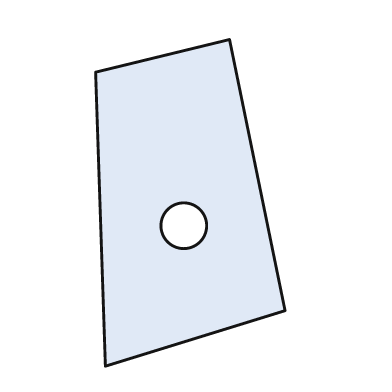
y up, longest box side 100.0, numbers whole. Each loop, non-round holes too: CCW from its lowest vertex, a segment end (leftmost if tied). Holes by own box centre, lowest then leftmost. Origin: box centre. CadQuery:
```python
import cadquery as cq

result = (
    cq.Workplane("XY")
    .moveTo(-26.0, -50.0)
    .lineTo(29.0, -33.0)
    .lineTo(12.0, 50.0)
    .lineTo(-29.0, 40.0)
    .close()
    .moveTo(-2.0, -7.0)
    .circle(7.0)
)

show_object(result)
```